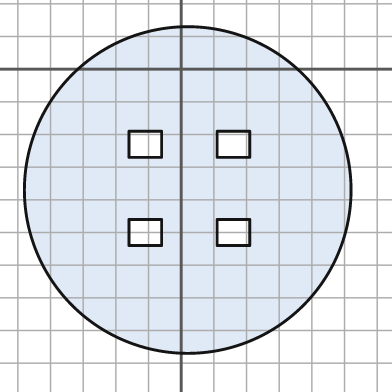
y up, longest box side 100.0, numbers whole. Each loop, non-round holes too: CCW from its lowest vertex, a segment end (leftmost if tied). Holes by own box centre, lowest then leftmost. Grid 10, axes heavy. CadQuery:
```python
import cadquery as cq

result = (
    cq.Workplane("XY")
    .moveTo(2.0, -37.0)
    .circle(50.0)
    .moveTo(-16.0, -54.0)
    .lineTo(-6.0, -54.0)
    .lineTo(-6.0, -46.0)
    .lineTo(-16.0, -46.0)
    .close()
    .moveTo(11.0, -54.0)
    .lineTo(21.0, -54.0)
    .lineTo(21.0, -46.0)
    .lineTo(11.0, -46.0)
    .close()
    .moveTo(-16.0, -27.0)
    .lineTo(-6.0, -27.0)
    .lineTo(-6.0, -19.0)
    .lineTo(-16.0, -19.0)
    .close()
    .moveTo(11.0, -27.0)
    .lineTo(21.0, -27.0)
    .lineTo(21.0, -19.0)
    .lineTo(11.0, -19.0)
    .close()
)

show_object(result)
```